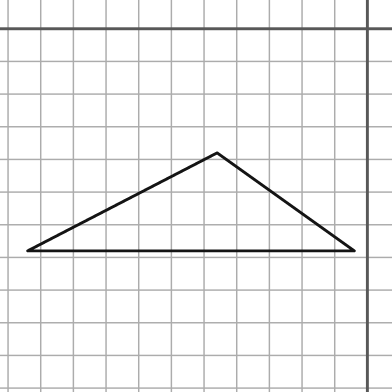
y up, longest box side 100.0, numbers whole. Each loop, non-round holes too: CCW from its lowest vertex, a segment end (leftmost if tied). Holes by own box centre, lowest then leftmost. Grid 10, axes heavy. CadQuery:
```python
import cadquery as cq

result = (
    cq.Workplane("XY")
    .moveTo(-104.0, -68.0)
    .lineTo(-4.0, -68.0)
    .lineTo(-46.0, -38.0)
    .close()
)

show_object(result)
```